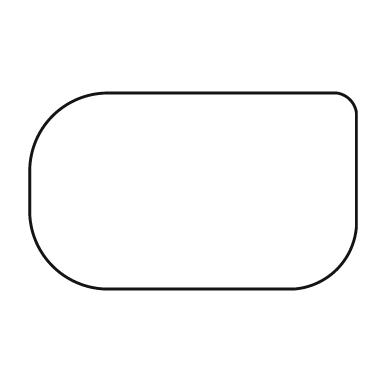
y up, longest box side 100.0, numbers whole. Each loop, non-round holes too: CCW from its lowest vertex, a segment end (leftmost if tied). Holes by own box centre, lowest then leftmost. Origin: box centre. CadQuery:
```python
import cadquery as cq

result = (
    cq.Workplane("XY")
    .moveTo(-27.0, -30.0)
    .lineTo(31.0, -30.0)
    .threePointArc((44.0, -24.0), (50.0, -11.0))
    .lineTo(50.0, 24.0)
    .threePointArc((48.0, 28.0), (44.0, 30.0))
    .lineTo(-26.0, 30.0)
    .threePointArc((-43.0, 23.0), (-50.0, 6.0))
    .lineTo(-50.0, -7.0)
    .threePointArc((-43.0, -23.0), (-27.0, -30.0))
    .close()
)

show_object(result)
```